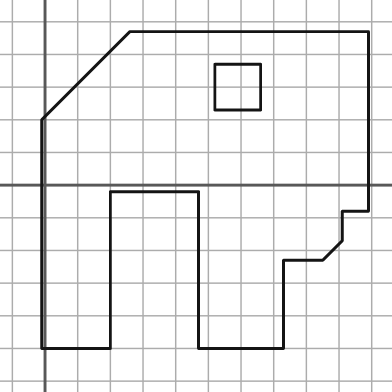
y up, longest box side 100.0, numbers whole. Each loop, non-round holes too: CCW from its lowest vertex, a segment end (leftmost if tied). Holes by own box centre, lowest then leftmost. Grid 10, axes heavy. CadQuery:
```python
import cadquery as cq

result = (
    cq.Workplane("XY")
    .moveTo(-1.0, -50.0)
    .lineTo(20.0, -50.0)
    .lineTo(20.0, -2.0)
    .lineTo(47.0, -2.0)
    .lineTo(47.0, -50.0)
    .lineTo(73.0, -50.0)
    .lineTo(73.0, -23.0)
    .lineTo(85.0, -23.0)
    .lineTo(91.0, -17.0)
    .lineTo(91.0, -8.0)
    .lineTo(99.0, -8.0)
    .lineTo(99.0, 47.0)
    .lineTo(26.0, 47.0)
    .lineTo(-1.0, 20.0)
    .close()
    .moveTo(52.0, 23.0)
    .lineTo(66.0, 23.0)
    .lineTo(66.0, 37.0)
    .lineTo(52.0, 37.0)
    .close()
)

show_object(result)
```